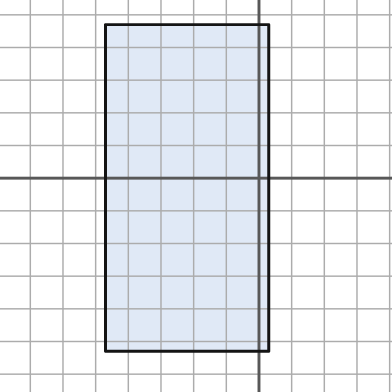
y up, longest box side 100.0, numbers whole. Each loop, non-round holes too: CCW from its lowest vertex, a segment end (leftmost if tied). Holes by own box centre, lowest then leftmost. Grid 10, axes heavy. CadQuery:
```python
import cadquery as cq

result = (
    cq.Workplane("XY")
    .moveTo(-47.0, -53.0)
    .lineTo(3.0, -53.0)
    .lineTo(3.0, 47.0)
    .lineTo(-47.0, 47.0)
    .close()
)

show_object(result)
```